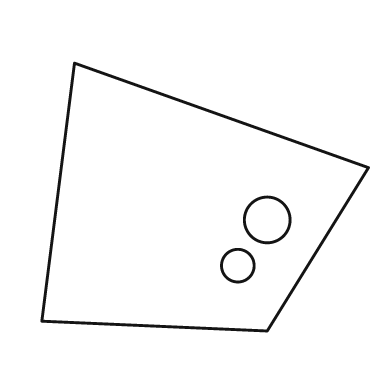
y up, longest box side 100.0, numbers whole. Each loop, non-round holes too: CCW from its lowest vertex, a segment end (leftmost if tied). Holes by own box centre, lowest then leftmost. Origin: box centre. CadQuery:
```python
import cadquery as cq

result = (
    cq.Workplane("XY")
    .moveTo(19.0, -41.0)
    .lineTo(50.0, 9.0)
    .lineTo(-40.0, 41.0)
    .lineTo(-50.0, -38.0)
    .close()
    .moveTo(10.0, -21.0)
    .circle(5.0)
    .moveTo(19.0, -7.0)
    .circle(7.0)
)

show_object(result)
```